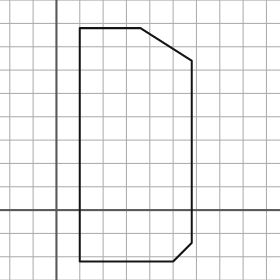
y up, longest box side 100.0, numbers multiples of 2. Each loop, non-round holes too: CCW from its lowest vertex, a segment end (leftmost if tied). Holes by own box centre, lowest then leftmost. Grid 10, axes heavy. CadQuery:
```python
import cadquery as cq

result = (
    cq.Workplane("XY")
    .moveTo(10.0, -22.0)
    .lineTo(50.0, -22.0)
    .lineTo(58.0, -14.0)
    .lineTo(58.0, 64.0)
    .lineTo(36.0, 78.0)
    .lineTo(10.0, 78.0)
    .close()
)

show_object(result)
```